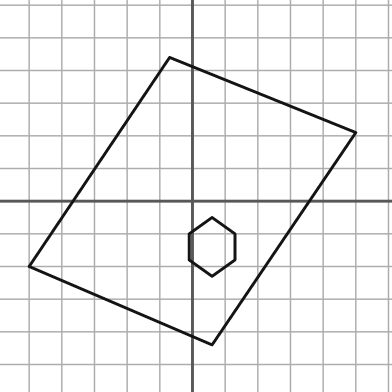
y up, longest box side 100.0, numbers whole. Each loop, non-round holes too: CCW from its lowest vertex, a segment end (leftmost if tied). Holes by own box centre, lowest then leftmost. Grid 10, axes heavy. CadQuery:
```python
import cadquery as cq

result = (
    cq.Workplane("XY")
    .moveTo(6.0, -44.0)
    .lineTo(50.0, 21.0)
    .lineTo(-7.0, 44.0)
    .lineTo(-50.0, -20.0)
    .close()
    .moveTo(6.0, -23.0)
    .lineTo(13.0, -18.0)
    .lineTo(13.0, -10.0)
    .lineTo(6.0, -5.0)
    .lineTo(-1.0, -10.0)
    .lineTo(-1.0, -18.0)
    .close()
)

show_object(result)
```